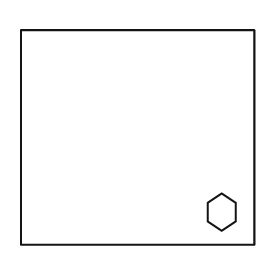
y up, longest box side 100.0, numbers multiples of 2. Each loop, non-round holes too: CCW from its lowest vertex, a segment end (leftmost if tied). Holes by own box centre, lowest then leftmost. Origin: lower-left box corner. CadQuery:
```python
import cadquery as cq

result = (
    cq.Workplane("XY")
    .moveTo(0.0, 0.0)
    .lineTo(100.0, 0.0)
    .lineTo(100.0, 92.0)
    .lineTo(0.0, 92.0)
    .close()
    .moveTo(86.0, 6.0)
    .lineTo(92.0, 10.0)
    .lineTo(92.0, 18.0)
    .lineTo(86.0, 22.0)
    .lineTo(80.0, 18.0)
    .lineTo(80.0, 10.0)
    .close()
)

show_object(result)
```